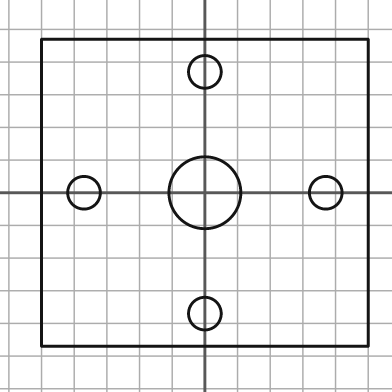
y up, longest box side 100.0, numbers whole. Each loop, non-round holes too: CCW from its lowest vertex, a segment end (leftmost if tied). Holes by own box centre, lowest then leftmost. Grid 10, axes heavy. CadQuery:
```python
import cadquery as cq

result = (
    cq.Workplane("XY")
    .moveTo(-50.0, -47.0)
    .lineTo(50.0, -47.0)
    .lineTo(50.0, 47.0)
    .lineTo(-50.0, 47.0)
    .close()
    .moveTo(0.0, -37.0)
    .circle(5.0)
    .moveTo(-37.0, 0.0)
    .circle(5.0)
    .moveTo(0.0, 0.0)
    .circle(11.0)
    .moveTo(37.0, 0.0)
    .circle(5.0)
    .moveTo(0.0, 37.0)
    .circle(5.0)
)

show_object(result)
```